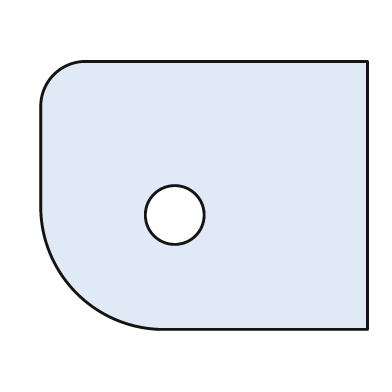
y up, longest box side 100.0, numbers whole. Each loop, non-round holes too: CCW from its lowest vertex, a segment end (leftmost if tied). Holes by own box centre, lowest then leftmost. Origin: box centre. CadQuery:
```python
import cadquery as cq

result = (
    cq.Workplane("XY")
    .moveTo(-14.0, -41.0)
    .lineTo(50.0, -41.0)
    .lineTo(50.0, 41.0)
    .lineTo(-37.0, 41.0)
    .threePointArc((-46.0, 37.0), (-50.0, 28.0))
    .lineTo(-50.0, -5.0)
    .threePointArc((-39.0, -30.0), (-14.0, -41.0))
    .close()
    .moveTo(-9.0, -6.0)
    .circle(9.0)
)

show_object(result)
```